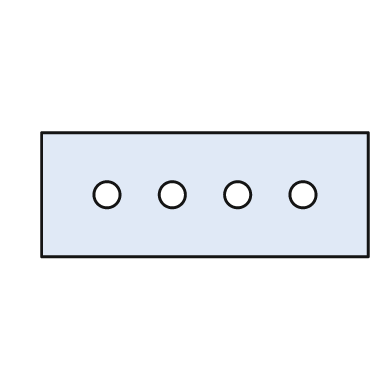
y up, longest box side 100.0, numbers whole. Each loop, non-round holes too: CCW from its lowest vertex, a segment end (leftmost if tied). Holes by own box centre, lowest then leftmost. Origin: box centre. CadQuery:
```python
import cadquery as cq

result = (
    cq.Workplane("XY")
    .moveTo(-50.0, -19.0)
    .lineTo(50.0, -19.0)
    .lineTo(50.0, 19.0)
    .lineTo(-50.0, 19.0)
    .close()
    .moveTo(-30.0, 0.0)
    .circle(4.0)
    .moveTo(-10.0, 0.0)
    .circle(4.0)
    .moveTo(10.0, 0.0)
    .circle(4.0)
    .moveTo(30.0, 0.0)
    .circle(4.0)
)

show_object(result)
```